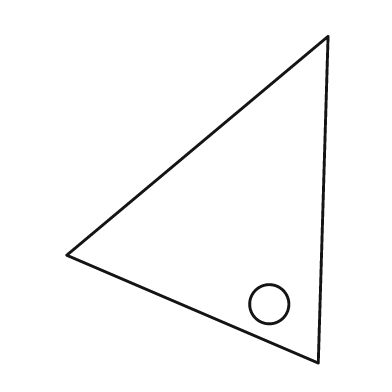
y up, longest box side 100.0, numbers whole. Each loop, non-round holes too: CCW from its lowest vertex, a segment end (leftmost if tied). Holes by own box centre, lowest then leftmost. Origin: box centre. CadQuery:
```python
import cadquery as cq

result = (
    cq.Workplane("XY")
    .moveTo(37.0, -50.0)
    .lineTo(40.0, 50.0)
    .lineTo(-40.0, -17.0)
    .close()
    .moveTo(22.0, -32.0)
    .circle(6.0)
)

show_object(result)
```